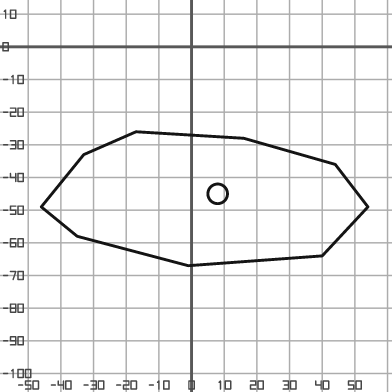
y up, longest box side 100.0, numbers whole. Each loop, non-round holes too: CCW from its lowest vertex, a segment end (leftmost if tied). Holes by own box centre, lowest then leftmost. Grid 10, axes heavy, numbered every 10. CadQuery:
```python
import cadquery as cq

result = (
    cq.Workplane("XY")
    .moveTo(-1.0, -67.0)
    .lineTo(40.0, -64.0)
    .lineTo(54.0, -49.0)
    .lineTo(44.0, -36.0)
    .lineTo(16.0, -28.0)
    .lineTo(-17.0, -26.0)
    .lineTo(-33.0, -33.0)
    .lineTo(-46.0, -49.0)
    .lineTo(-35.0, -58.0)
    .close()
    .moveTo(8.0, -45.0)
    .circle(3.0)
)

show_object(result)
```